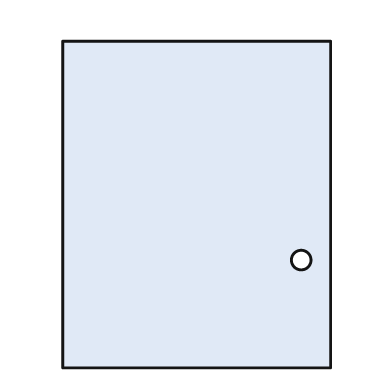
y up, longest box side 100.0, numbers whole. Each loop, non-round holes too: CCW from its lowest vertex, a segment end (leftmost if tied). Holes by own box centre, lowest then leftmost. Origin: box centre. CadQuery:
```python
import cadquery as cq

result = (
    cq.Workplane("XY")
    .moveTo(-41.0, -50.0)
    .lineTo(41.0, -50.0)
    .lineTo(41.0, 50.0)
    .lineTo(-41.0, 50.0)
    .close()
    .moveTo(32.0, -17.0)
    .circle(3.0)
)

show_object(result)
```